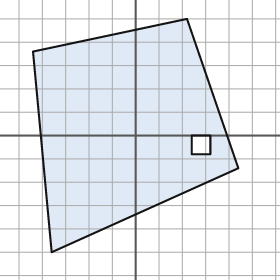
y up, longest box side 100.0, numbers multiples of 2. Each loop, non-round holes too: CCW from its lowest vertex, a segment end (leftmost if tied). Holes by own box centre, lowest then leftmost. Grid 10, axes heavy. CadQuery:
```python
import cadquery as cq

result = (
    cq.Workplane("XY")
    .moveTo(-36.0, -50.0)
    .lineTo(44.0, -14.0)
    .lineTo(22.0, 50.0)
    .lineTo(-44.0, 36.0)
    .close()
    .moveTo(24.0, -8.0)
    .lineTo(32.0, -8.0)
    .lineTo(32.0, 0.0)
    .lineTo(24.0, 0.0)
    .close()
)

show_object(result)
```